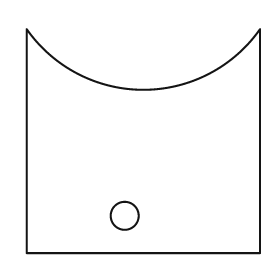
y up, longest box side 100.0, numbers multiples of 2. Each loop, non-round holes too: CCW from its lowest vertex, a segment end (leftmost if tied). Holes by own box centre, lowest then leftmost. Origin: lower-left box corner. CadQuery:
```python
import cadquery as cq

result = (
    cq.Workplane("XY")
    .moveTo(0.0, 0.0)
    .lineTo(100.0, 0.0)
    .lineTo(100.0, 96.0)
    .threePointArc((50.0, 70.0), (0.0, 96.0))
    .close()
    .moveTo(42.0, 16.0)
    .circle(6.0)
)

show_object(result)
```